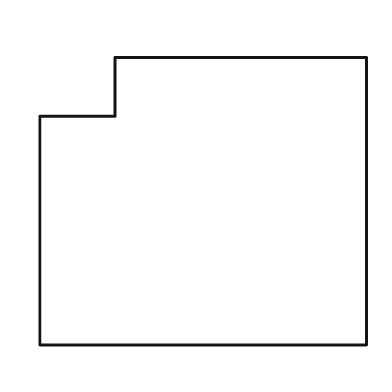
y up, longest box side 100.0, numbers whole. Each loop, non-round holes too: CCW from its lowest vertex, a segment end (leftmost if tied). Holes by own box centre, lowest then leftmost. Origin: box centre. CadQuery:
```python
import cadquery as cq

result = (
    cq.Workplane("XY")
    .moveTo(-50.0, -44.0)
    .lineTo(50.0, -44.0)
    .lineTo(50.0, 44.0)
    .lineTo(-27.0, 44.0)
    .lineTo(-27.0, 26.0)
    .lineTo(-50.0, 26.0)
    .close()
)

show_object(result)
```